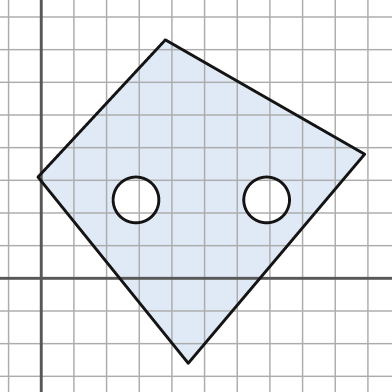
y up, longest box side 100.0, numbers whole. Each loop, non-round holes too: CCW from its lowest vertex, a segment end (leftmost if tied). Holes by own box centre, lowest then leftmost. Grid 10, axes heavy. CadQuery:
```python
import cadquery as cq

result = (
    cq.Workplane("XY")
    .moveTo(45.0, -26.0)
    .lineTo(99.0, 38.0)
    .lineTo(38.0, 73.0)
    .lineTo(-1.0, 31.0)
    .close()
    .moveTo(29.0, 24.0)
    .circle(7.0)
    .moveTo(69.0, 24.0)
    .circle(7.0)
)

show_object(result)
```